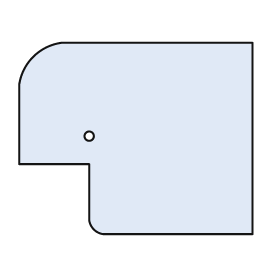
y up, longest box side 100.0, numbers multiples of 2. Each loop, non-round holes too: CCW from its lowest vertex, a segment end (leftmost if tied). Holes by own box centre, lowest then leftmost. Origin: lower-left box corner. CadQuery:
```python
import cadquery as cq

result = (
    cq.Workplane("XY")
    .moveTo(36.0, 0.0)
    .lineTo(100.0, 0.0)
    .lineTo(100.0, 82.0)
    .lineTo(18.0, 82.0)
    .threePointArc((6.0, 76.0), (0.0, 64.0))
    .lineTo(0.0, 30.0)
    .lineTo(30.0, 30.0)
    .lineTo(30.0, 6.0)
    .threePointArc((32.0, 2.0), (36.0, 0.0))
    .close()
    .moveTo(30.0, 42.0)
    .circle(2.0)
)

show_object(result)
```